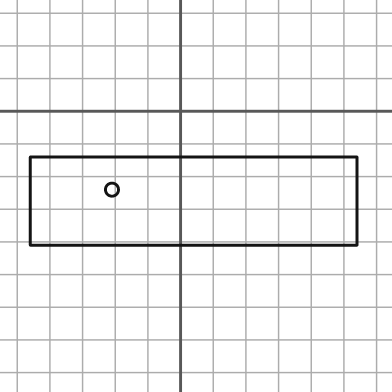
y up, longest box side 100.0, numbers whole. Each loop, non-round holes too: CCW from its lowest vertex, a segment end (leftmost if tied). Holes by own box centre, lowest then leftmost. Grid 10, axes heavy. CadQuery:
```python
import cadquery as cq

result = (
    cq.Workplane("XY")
    .moveTo(-46.0, -41.0)
    .lineTo(54.0, -41.0)
    .lineTo(54.0, -14.0)
    .lineTo(-46.0, -14.0)
    .close()
    .moveTo(-21.0, -24.0)
    .circle(2.0)
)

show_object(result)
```